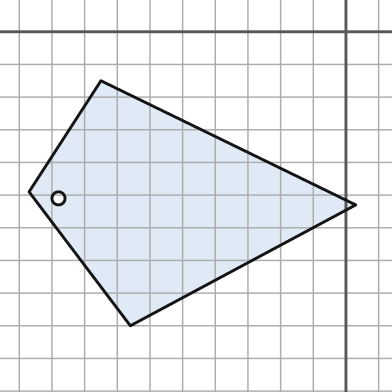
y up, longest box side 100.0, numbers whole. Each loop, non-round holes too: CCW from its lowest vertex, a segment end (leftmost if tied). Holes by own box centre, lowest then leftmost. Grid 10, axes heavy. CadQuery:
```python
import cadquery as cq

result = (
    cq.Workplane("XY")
    .moveTo(-66.0, -90.0)
    .lineTo(3.0, -53.0)
    .lineTo(-75.0, -15.0)
    .lineTo(-97.0, -49.0)
    .close()
    .moveTo(-88.0, -51.0)
    .circle(2.0)
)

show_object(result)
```